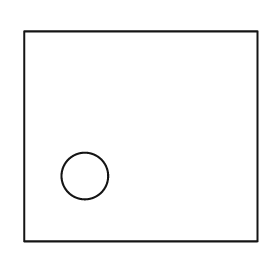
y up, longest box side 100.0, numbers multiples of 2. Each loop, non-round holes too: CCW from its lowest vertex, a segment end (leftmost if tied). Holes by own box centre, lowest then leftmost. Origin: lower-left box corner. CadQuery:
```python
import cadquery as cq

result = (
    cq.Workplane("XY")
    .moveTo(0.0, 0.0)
    .lineTo(100.0, 0.0)
    .lineTo(100.0, 90.0)
    .lineTo(0.0, 90.0)
    .close()
    .moveTo(26.0, 28.0)
    .circle(10.0)
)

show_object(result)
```